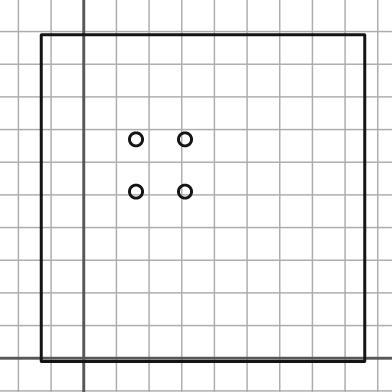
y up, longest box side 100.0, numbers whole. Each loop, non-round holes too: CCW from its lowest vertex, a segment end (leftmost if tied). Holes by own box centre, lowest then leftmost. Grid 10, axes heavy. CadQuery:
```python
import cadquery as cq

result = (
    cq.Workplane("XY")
    .moveTo(-13.0, -1.0)
    .lineTo(86.0, -1.0)
    .lineTo(86.0, 99.0)
    .lineTo(-13.0, 99.0)
    .close()
    .moveTo(16.0, 51.0)
    .circle(2.0)
    .moveTo(31.0, 51.0)
    .circle(2.0)
    .moveTo(16.0, 67.0)
    .circle(2.0)
    .moveTo(31.0, 67.0)
    .circle(2.0)
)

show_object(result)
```